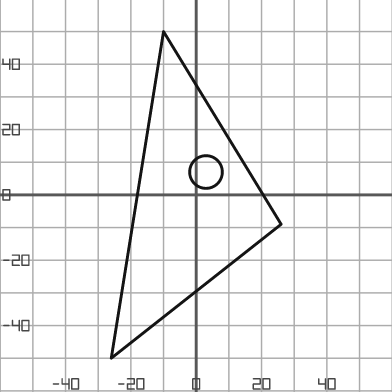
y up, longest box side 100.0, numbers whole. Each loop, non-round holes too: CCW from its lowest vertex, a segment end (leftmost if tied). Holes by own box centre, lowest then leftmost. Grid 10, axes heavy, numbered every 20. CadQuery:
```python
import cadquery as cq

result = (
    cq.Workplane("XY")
    .moveTo(-26.0, -50.0)
    .lineTo(26.0, -9.0)
    .lineTo(-10.0, 50.0)
    .close()
    .moveTo(3.0, 7.0)
    .circle(5.0)
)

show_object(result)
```